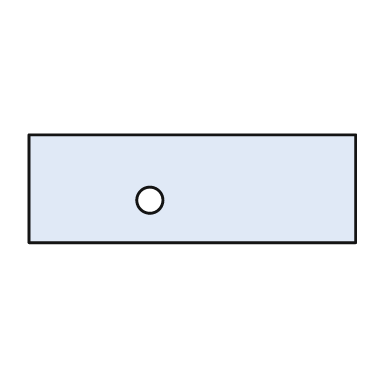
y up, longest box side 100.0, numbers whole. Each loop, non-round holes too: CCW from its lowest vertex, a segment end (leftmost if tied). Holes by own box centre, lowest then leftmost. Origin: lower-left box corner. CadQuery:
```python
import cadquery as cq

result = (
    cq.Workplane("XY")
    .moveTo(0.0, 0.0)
    .lineTo(100.0, 0.0)
    .lineTo(100.0, 33.0)
    .lineTo(0.0, 33.0)
    .close()
    .moveTo(37.0, 13.0)
    .circle(4.0)
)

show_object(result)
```